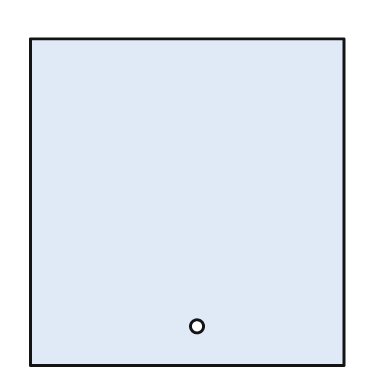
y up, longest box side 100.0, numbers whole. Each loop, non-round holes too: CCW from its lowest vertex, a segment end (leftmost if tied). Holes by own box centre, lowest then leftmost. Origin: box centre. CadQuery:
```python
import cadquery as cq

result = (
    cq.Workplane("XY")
    .moveTo(-48.0, -50.0)
    .lineTo(48.0, -50.0)
    .lineTo(48.0, 50.0)
    .lineTo(-48.0, 50.0)
    .close()
    .moveTo(3.0, -38.0)
    .circle(2.0)
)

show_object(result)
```